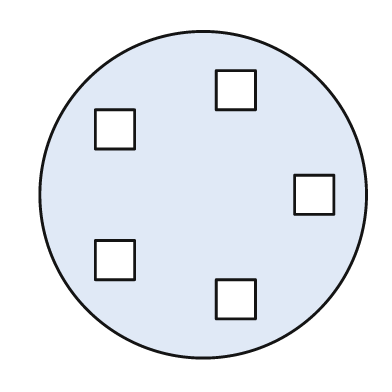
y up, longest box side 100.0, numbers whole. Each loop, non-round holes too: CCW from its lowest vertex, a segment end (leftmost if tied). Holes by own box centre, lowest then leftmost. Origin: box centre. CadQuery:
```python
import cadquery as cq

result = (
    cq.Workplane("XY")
    .moveTo(0.0, 0.0)
    .circle(50.0)
    .moveTo(4.0, -38.0)
    .lineTo(16.0, -38.0)
    .lineTo(16.0, -26.0)
    .lineTo(4.0, -26.0)
    .close()
    .moveTo(-33.0, -26.0)
    .lineTo(-21.0, -26.0)
    .lineTo(-21.0, -14.0)
    .lineTo(-33.0, -14.0)
    .close()
    .moveTo(28.0, -6.0)
    .lineTo(40.0, -6.0)
    .lineTo(40.0, 6.0)
    .lineTo(28.0, 6.0)
    .close()
    .moveTo(-33.0, 14.0)
    .lineTo(-21.0, 14.0)
    .lineTo(-21.0, 26.0)
    .lineTo(-33.0, 26.0)
    .close()
    .moveTo(4.0, 26.0)
    .lineTo(16.0, 26.0)
    .lineTo(16.0, 38.0)
    .lineTo(4.0, 38.0)
    .close()
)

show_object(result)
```